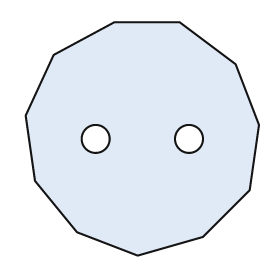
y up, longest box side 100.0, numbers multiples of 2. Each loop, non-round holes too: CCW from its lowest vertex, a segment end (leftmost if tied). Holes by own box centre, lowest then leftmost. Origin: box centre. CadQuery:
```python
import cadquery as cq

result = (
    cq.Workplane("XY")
    .moveTo(-2.0, -50.0)
    .lineTo(26.0, -42.0)
    .lineTo(46.0, -22.0)
    .lineTo(50.0, 6.0)
    .lineTo(40.0, 32.0)
    .lineTo(16.0, 50.0)
    .lineTo(-12.0, 50.0)
    .lineTo(-38.0, 36.0)
    .lineTo(-50.0, 10.0)
    .lineTo(-46.0, -18.0)
    .lineTo(-28.0, -40.0)
    .close()
    .moveTo(-20.0, 0.0)
    .circle(6.0)
    .moveTo(20.0, 0.0)
    .circle(6.0)
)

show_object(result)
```